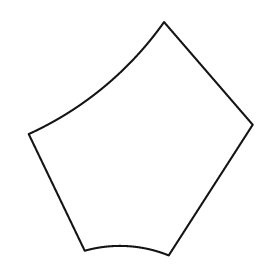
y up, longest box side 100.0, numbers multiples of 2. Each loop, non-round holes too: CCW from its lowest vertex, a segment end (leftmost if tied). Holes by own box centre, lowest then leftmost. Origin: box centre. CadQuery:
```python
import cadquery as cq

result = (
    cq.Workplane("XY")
    .moveTo(12.0, -50.0)
    .lineTo(48.0, 6.0)
    .lineTo(10.0, 50.0)
    .threePointArc((-16.0, 22.0), (-48.0, 2.0))
    .lineTo(-24.0, -48.0)
    .threePointArc((-6.0, -46.0), (12.0, -50.0))
    .close()
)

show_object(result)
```